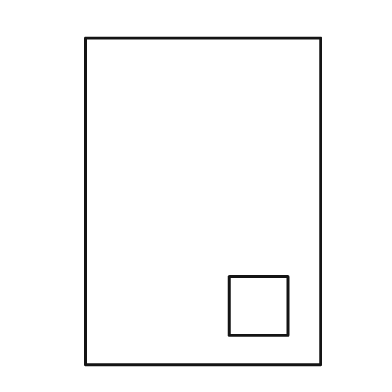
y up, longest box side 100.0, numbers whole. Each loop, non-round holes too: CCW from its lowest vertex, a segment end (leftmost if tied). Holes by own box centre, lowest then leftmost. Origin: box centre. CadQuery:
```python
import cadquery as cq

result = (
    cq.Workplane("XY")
    .moveTo(-36.0, -50.0)
    .lineTo(36.0, -50.0)
    .lineTo(36.0, 50.0)
    .lineTo(-36.0, 50.0)
    .close()
    .moveTo(8.0, -41.0)
    .lineTo(26.0, -41.0)
    .lineTo(26.0, -23.0)
    .lineTo(8.0, -23.0)
    .close()
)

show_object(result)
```